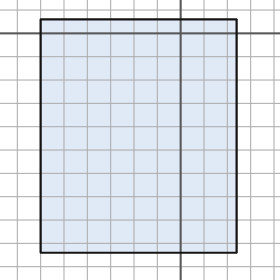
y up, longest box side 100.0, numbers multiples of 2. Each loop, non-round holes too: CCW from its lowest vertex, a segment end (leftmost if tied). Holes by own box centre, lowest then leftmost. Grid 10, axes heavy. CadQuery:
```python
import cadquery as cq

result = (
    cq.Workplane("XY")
    .moveTo(-60.0, -94.0)
    .lineTo(24.0, -94.0)
    .lineTo(24.0, 6.0)
    .lineTo(-60.0, 6.0)
    .close()
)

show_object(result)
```